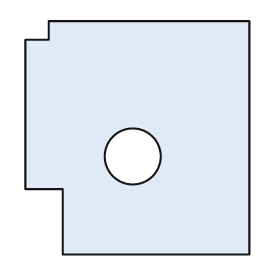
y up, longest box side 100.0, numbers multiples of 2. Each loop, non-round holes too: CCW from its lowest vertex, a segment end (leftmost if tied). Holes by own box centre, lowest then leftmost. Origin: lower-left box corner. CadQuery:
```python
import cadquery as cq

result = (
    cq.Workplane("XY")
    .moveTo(16.0, 0.0)
    .lineTo(96.0, 0.0)
    .lineTo(96.0, 100.0)
    .lineTo(10.0, 100.0)
    .lineTo(10.0, 92.0)
    .lineTo(0.0, 92.0)
    .lineTo(0.0, 28.0)
    .lineTo(16.0, 28.0)
    .close()
    .moveTo(46.0, 42.0)
    .circle(12.0)
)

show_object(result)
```